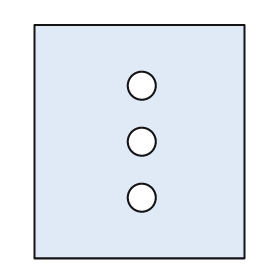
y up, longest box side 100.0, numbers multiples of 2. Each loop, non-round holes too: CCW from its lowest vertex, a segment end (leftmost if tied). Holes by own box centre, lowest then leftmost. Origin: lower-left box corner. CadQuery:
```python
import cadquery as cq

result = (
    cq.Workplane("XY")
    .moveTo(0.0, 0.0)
    .lineTo(90.0, 0.0)
    .lineTo(90.0, 100.0)
    .lineTo(0.0, 100.0)
    .close()
    .moveTo(46.0, 26.0)
    .circle(6.0)
    .moveTo(46.0, 50.0)
    .circle(6.0)
    .moveTo(46.0, 74.0)
    .circle(6.0)
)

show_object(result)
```